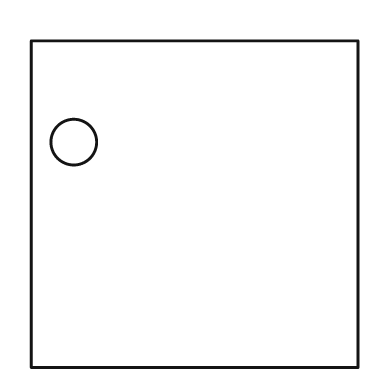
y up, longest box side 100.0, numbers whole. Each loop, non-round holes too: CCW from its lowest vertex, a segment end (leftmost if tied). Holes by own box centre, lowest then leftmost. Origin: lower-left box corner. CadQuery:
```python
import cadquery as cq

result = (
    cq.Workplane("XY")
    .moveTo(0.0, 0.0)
    .lineTo(100.0, 0.0)
    .lineTo(100.0, 100.0)
    .lineTo(0.0, 100.0)
    .close()
    .moveTo(13.0, 69.0)
    .circle(7.0)
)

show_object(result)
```